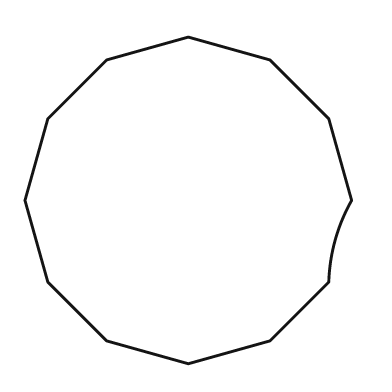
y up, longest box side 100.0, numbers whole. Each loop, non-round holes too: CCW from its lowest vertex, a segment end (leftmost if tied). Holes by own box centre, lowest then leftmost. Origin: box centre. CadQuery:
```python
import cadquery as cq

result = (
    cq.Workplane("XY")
    .moveTo(0.0, -50.0)
    .lineTo(25.0, -43.0)
    .lineTo(43.0, -25.0)
    .threePointArc((45.0, -12.0), (50.0, 0.0))
    .lineTo(43.0, 25.0)
    .lineTo(25.0, 43.0)
    .lineTo(0.0, 50.0)
    .lineTo(-25.0, 43.0)
    .lineTo(-43.0, 25.0)
    .lineTo(-50.0, 0.0)
    .lineTo(-43.0, -25.0)
    .lineTo(-25.0, -43.0)
    .close()
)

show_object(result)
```